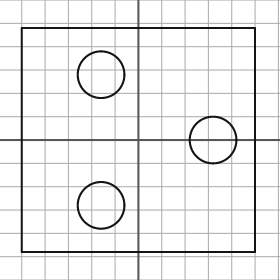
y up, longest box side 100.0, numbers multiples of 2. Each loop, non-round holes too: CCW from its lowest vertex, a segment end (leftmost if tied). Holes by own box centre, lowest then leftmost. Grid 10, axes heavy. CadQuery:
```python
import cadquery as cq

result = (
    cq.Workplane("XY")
    .moveTo(-50.0, -48.0)
    .lineTo(50.0, -48.0)
    .lineTo(50.0, 48.0)
    .lineTo(-50.0, 48.0)
    .close()
    .moveTo(-16.0, -28.0)
    .circle(10.0)
    .moveTo(32.0, 0.0)
    .circle(10.0)
    .moveTo(-16.0, 28.0)
    .circle(10.0)
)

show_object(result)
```